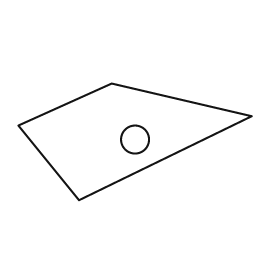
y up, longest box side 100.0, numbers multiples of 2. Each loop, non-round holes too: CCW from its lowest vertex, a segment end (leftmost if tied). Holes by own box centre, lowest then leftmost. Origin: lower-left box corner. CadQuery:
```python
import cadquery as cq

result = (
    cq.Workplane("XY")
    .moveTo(26.0, 0.0)
    .lineTo(100.0, 36.0)
    .lineTo(40.0, 50.0)
    .lineTo(0.0, 32.0)
    .close()
    .moveTo(50.0, 26.0)
    .circle(6.0)
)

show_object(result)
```